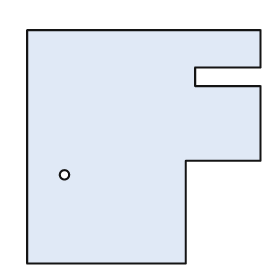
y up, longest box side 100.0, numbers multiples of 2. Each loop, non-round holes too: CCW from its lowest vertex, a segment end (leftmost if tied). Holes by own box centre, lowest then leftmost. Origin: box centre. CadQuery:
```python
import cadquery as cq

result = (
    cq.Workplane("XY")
    .moveTo(-50.0, -50.0)
    .lineTo(18.0, -50.0)
    .lineTo(18.0, -6.0)
    .lineTo(50.0, -6.0)
    .lineTo(50.0, 26.0)
    .lineTo(22.0, 26.0)
    .lineTo(22.0, 34.0)
    .lineTo(50.0, 34.0)
    .lineTo(50.0, 50.0)
    .lineTo(-50.0, 50.0)
    .close()
    .moveTo(-34.0, -12.0)
    .circle(2.0)
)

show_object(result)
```